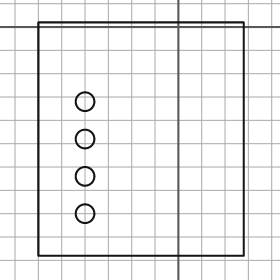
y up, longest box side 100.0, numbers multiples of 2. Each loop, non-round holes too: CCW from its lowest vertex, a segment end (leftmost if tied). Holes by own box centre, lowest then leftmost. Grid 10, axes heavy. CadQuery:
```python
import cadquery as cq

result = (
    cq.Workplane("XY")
    .moveTo(-60.0, -98.0)
    .lineTo(28.0, -98.0)
    .lineTo(28.0, 2.0)
    .lineTo(-60.0, 2.0)
    .close()
    .moveTo(-40.0, -80.0)
    .circle(4.0)
    .moveTo(-40.0, -64.0)
    .circle(4.0)
    .moveTo(-40.0, -48.0)
    .circle(4.0)
    .moveTo(-40.0, -32.0)
    .circle(4.0)
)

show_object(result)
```